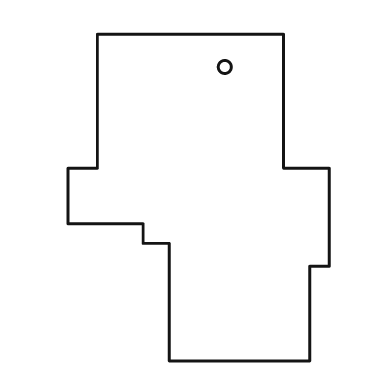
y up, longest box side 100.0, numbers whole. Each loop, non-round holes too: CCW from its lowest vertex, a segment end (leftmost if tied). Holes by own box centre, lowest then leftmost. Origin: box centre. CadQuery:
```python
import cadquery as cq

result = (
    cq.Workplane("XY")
    .moveTo(-9.0, -50.0)
    .lineTo(34.0, -50.0)
    .lineTo(34.0, -21.0)
    .lineTo(40.0, -21.0)
    .lineTo(40.0, 9.0)
    .lineTo(26.0, 9.0)
    .lineTo(26.0, 50.0)
    .lineTo(-31.0, 50.0)
    .lineTo(-31.0, 9.0)
    .lineTo(-40.0, 9.0)
    .lineTo(-40.0, -8.0)
    .lineTo(-17.0, -8.0)
    .lineTo(-17.0, -14.0)
    .lineTo(-9.0, -14.0)
    .close()
    .moveTo(8.0, 40.0)
    .circle(2.0)
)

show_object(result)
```